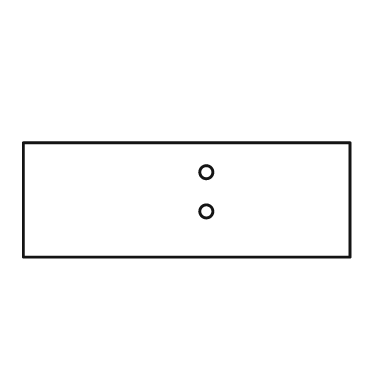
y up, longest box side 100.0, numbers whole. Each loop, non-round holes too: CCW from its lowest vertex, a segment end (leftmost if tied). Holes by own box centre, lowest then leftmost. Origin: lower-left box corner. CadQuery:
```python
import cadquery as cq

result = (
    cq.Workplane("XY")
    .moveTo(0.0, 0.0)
    .lineTo(100.0, 0.0)
    .lineTo(100.0, 35.0)
    .lineTo(0.0, 35.0)
    .close()
    .moveTo(56.0, 14.0)
    .circle(2.0)
    .moveTo(56.0, 26.0)
    .circle(2.0)
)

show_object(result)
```